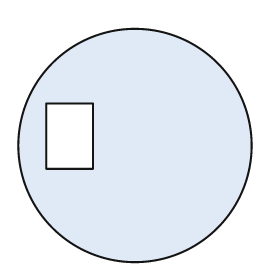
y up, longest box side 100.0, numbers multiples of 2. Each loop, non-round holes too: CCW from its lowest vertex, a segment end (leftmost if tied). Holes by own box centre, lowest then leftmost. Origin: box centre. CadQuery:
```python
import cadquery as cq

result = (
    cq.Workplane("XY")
    .moveTo(0.0, 0.0)
    .circle(50.0)
    .moveTo(-38.0, -10.0)
    .lineTo(-18.0, -10.0)
    .lineTo(-18.0, 18.0)
    .lineTo(-38.0, 18.0)
    .close()
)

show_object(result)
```